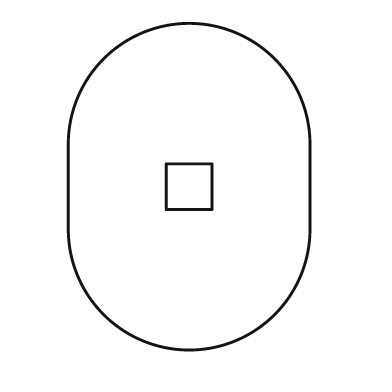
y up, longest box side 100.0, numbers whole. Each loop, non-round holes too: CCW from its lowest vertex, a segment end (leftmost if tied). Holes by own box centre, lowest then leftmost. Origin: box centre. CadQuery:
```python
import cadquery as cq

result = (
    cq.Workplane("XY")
    .moveTo(-37.0, -13.0)
    .threePointArc((0.0, -50.0), (37.0, -13.0))
    .lineTo(37.0, 13.0)
    .threePointArc((0.0, 50.0), (-37.0, 13.0))
    .close()
    .moveTo(-7.0, -7.0)
    .lineTo(7.0, -7.0)
    .lineTo(7.0, 7.0)
    .lineTo(-7.0, 7.0)
    .close()
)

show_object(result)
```